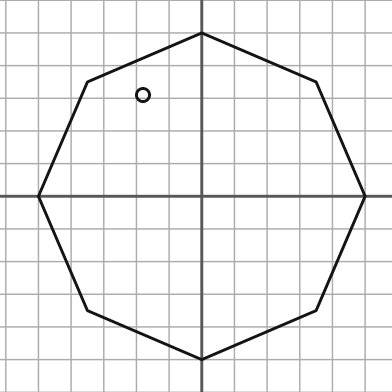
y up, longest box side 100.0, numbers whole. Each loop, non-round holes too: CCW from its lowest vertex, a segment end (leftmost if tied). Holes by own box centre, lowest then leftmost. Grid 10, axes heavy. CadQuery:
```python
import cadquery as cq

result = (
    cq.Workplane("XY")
    .moveTo(0.0, -50.0)
    .lineTo(35.0, -35.0)
    .lineTo(50.0, 0.0)
    .lineTo(35.0, 35.0)
    .lineTo(0.0, 50.0)
    .lineTo(-35.0, 35.0)
    .lineTo(-50.0, 0.0)
    .lineTo(-35.0, -35.0)
    .close()
    .moveTo(-18.0, 31.0)
    .circle(2.0)
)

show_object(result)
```